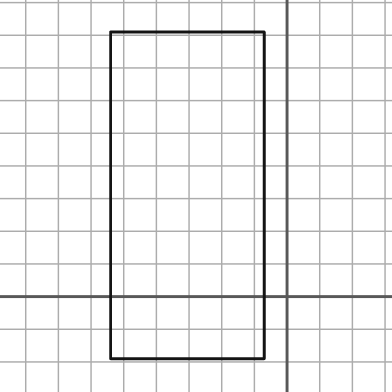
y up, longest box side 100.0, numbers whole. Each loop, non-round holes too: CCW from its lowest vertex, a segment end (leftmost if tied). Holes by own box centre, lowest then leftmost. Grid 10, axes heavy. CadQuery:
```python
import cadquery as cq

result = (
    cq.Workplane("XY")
    .moveTo(-54.0, -19.0)
    .lineTo(-7.0, -19.0)
    .lineTo(-7.0, 81.0)
    .lineTo(-54.0, 81.0)
    .close()
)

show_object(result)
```